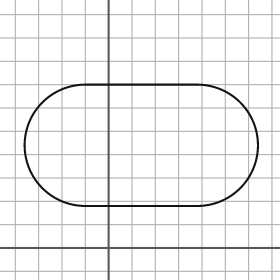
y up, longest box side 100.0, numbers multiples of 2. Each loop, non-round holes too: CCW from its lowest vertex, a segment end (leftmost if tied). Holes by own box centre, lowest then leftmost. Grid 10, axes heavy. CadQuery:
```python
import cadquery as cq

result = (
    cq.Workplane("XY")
    .moveTo(-10.0, 18.0)
    .lineTo(38.0, 18.0)
    .threePointArc((64.0, 44.0), (38.0, 70.0))
    .lineTo(-10.0, 70.0)
    .threePointArc((-36.0, 44.0), (-10.0, 18.0))
    .close()
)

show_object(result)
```